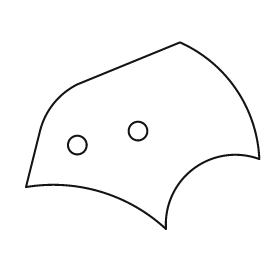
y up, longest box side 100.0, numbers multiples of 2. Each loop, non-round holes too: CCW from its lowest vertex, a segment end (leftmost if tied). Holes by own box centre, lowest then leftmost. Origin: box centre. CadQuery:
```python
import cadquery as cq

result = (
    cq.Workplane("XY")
    .moveTo(10.0, -40.0)
    .threePointArc((22.0, -14.0), (50.0, -10.0))
    .threePointArc((40.0, 20.0), (16.0, 40.0))
    .lineTo(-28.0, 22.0)
    .threePointArc((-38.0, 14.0), (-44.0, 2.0))
    .lineTo(-50.0, -22.0)
    .threePointArc((-18.0, -24.0), (10.0, -40.0))
    .close()
    .moveTo(-28.0, -4.0)
    .circle(4.0)
    .moveTo(-2.0, 2.0)
    .circle(4.0)
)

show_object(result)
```